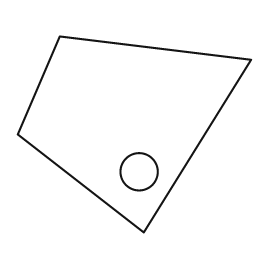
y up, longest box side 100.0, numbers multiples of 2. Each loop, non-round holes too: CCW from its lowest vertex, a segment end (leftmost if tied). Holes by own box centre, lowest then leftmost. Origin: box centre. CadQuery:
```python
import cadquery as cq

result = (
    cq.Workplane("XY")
    .moveTo(4.0, -42.0)
    .lineTo(50.0, 32.0)
    .lineTo(-32.0, 42.0)
    .lineTo(-50.0, 0.0)
    .close()
    .moveTo(2.0, -16.0)
    .circle(8.0)
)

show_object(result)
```